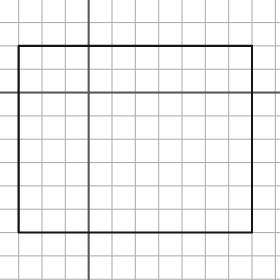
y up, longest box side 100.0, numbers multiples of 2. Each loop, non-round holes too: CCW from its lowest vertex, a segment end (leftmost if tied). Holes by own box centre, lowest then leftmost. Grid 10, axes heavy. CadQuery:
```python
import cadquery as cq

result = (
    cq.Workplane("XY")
    .moveTo(-30.0, -60.0)
    .lineTo(70.0, -60.0)
    .lineTo(70.0, 20.0)
    .lineTo(-30.0, 20.0)
    .close()
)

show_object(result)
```